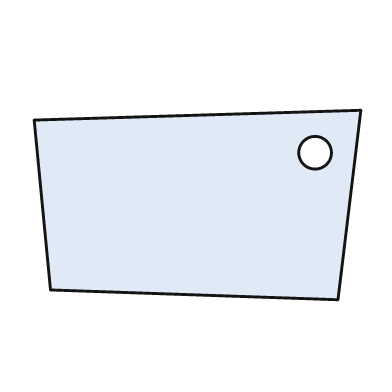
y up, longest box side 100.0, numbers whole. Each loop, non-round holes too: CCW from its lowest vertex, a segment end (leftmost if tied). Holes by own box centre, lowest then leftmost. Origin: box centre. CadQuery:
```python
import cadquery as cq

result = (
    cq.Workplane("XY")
    .moveTo(43.0, -29.0)
    .lineTo(50.0, 29.0)
    .lineTo(-50.0, 26.0)
    .lineTo(-45.0, -26.0)
    .close()
    .moveTo(36.0, 16.0)
    .circle(5.0)
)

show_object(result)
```